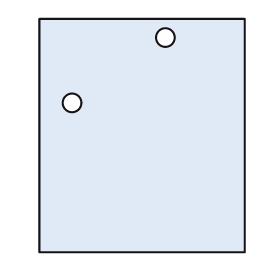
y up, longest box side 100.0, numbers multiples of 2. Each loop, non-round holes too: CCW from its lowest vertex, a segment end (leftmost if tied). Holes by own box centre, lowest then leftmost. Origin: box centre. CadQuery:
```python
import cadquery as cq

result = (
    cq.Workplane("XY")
    .moveTo(-44.0, -50.0)
    .lineTo(44.0, -50.0)
    .lineTo(44.0, 50.0)
    .lineTo(-44.0, 50.0)
    .close()
    .moveTo(-30.0, 14.0)
    .circle(4.0)
    .moveTo(10.0, 42.0)
    .circle(4.0)
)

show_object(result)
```